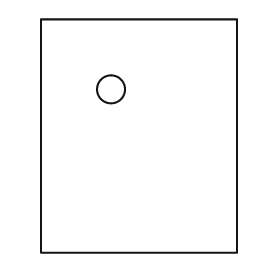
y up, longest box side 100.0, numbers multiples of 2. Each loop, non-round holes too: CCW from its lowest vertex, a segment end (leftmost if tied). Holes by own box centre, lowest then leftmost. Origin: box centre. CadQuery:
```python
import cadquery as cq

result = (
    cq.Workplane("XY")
    .moveTo(-42.0, -50.0)
    .lineTo(42.0, -50.0)
    .lineTo(42.0, 50.0)
    .lineTo(-42.0, 50.0)
    .close()
    .moveTo(-12.0, 20.0)
    .circle(6.0)
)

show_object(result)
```